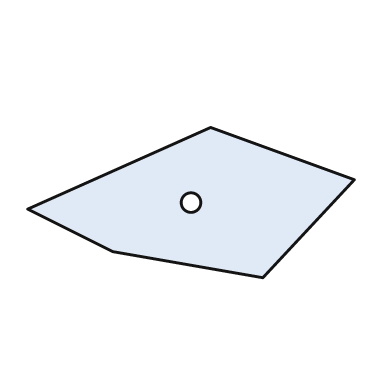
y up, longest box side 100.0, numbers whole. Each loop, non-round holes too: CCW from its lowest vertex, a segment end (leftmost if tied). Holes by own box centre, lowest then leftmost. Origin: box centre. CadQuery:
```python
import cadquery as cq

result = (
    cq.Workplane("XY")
    .moveTo(22.0, -23.0)
    .lineTo(50.0, 7.0)
    .lineTo(6.0, 23.0)
    .lineTo(-50.0, -2.0)
    .lineTo(-24.0, -15.0)
    .close()
    .moveTo(0.0, 0.0)
    .circle(3.0)
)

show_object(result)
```